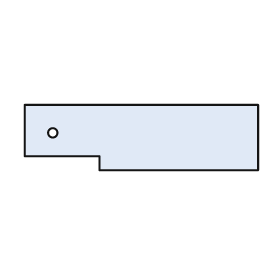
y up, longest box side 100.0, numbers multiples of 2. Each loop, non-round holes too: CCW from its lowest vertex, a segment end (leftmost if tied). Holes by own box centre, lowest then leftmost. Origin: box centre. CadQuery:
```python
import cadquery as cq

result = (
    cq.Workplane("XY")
    .moveTo(-18.0, -14.0)
    .lineTo(50.0, -14.0)
    .lineTo(50.0, 14.0)
    .lineTo(-50.0, 14.0)
    .lineTo(-50.0, -8.0)
    .lineTo(-18.0, -8.0)
    .close()
    .moveTo(-38.0, 2.0)
    .circle(2.0)
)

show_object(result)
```